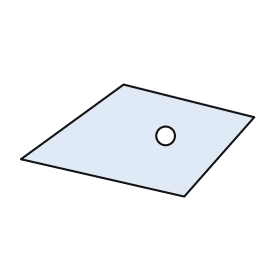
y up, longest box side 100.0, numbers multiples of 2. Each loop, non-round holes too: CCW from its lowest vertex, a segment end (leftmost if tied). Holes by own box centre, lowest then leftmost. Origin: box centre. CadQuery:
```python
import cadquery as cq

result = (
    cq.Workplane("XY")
    .moveTo(20.0, -24.0)
    .lineTo(50.0, 10.0)
    .lineTo(-6.0, 24.0)
    .lineTo(-50.0, -8.0)
    .close()
    .moveTo(12.0, 2.0)
    .circle(4.0)
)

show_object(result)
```